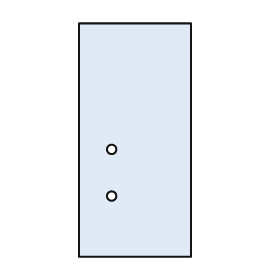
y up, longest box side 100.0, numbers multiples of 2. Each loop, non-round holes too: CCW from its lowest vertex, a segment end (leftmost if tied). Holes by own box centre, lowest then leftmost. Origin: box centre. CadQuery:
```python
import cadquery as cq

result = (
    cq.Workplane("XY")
    .moveTo(-24.0, -50.0)
    .lineTo(24.0, -50.0)
    .lineTo(24.0, 50.0)
    .lineTo(-24.0, 50.0)
    .close()
    .moveTo(-10.0, -24.0)
    .circle(2.0)
    .moveTo(-10.0, -4.0)
    .circle(2.0)
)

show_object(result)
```